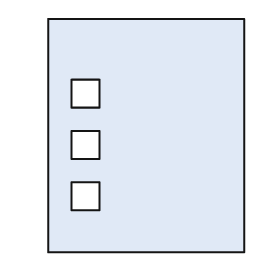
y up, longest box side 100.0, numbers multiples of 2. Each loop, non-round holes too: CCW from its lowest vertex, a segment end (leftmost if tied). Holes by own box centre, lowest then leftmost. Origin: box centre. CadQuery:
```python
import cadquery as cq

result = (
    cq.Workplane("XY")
    .moveTo(-42.0, -50.0)
    .lineTo(42.0, -50.0)
    .lineTo(42.0, 50.0)
    .lineTo(-42.0, 50.0)
    .close()
    .moveTo(-32.0, -32.0)
    .lineTo(-20.0, -32.0)
    .lineTo(-20.0, -20.0)
    .lineTo(-32.0, -20.0)
    .close()
    .moveTo(-32.0, -10.0)
    .lineTo(-20.0, -10.0)
    .lineTo(-20.0, 2.0)
    .lineTo(-32.0, 2.0)
    .close()
    .moveTo(-32.0, 12.0)
    .lineTo(-20.0, 12.0)
    .lineTo(-20.0, 24.0)
    .lineTo(-32.0, 24.0)
    .close()
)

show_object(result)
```